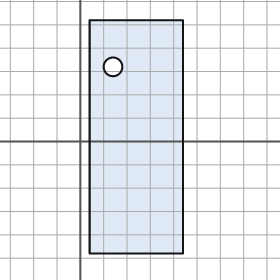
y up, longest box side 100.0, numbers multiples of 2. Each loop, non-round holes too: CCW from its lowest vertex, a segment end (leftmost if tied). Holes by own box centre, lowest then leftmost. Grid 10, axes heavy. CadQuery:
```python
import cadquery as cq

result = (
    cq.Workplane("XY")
    .moveTo(4.0, -48.0)
    .lineTo(44.0, -48.0)
    .lineTo(44.0, 52.0)
    .lineTo(4.0, 52.0)
    .close()
    .moveTo(14.0, 32.0)
    .circle(4.0)
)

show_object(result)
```